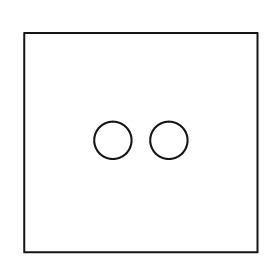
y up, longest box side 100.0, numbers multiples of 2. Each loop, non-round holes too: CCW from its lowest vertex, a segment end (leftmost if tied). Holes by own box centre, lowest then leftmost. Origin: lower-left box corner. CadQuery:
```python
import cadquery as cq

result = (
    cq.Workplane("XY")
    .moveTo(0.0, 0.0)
    .lineTo(100.0, 0.0)
    .lineTo(100.0, 94.0)
    .lineTo(0.0, 94.0)
    .close()
    .moveTo(38.0, 48.0)
    .circle(8.0)
    .moveTo(62.0, 48.0)
    .circle(8.0)
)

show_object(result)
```